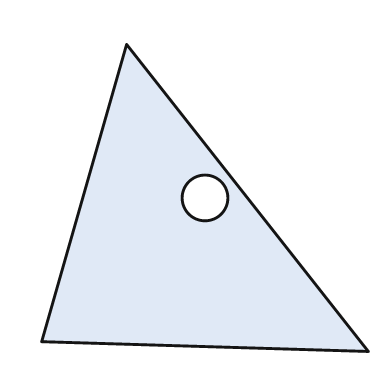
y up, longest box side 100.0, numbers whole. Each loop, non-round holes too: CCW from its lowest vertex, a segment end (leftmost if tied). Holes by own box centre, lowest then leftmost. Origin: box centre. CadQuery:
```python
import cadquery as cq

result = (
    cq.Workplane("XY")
    .moveTo(50.0, -47.0)
    .lineTo(-24.0, 47.0)
    .lineTo(-50.0, -44.0)
    .close()
    .moveTo(0.0, 0.0)
    .circle(7.0)
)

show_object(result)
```